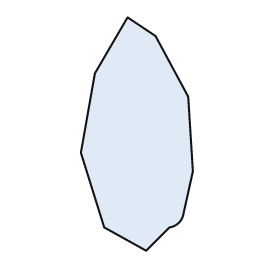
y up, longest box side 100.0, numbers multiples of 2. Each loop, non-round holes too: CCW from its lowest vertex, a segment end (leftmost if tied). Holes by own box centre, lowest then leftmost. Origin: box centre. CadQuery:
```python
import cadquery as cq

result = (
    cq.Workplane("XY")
    .moveTo(4.0, -50.0)
    .lineTo(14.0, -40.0)
    .threePointArc((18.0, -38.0), (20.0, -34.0))
    .lineTo(24.0, -16.0)
    .lineTo(22.0, 16.0)
    .lineTo(8.0, 42.0)
    .lineTo(-4.0, 50.0)
    .lineTo(-18.0, 26.0)
    .lineTo(-24.0, -8.0)
    .lineTo(-14.0, -40.0)
    .close()
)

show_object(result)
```